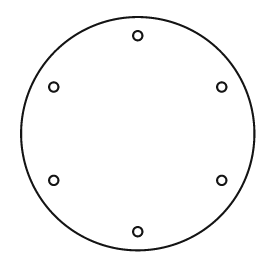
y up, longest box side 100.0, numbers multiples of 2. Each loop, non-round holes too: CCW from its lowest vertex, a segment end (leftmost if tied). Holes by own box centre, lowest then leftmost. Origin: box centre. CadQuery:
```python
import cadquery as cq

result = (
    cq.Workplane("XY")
    .moveTo(0.0, 0.0)
    .circle(50.0)
    .moveTo(0.0, -42.0)
    .circle(2.0)
    .moveTo(-36.0, -20.0)
    .circle(2.0)
    .moveTo(36.0, -20.0)
    .circle(2.0)
    .moveTo(-36.0, 20.0)
    .circle(2.0)
    .moveTo(36.0, 20.0)
    .circle(2.0)
    .moveTo(0.0, 42.0)
    .circle(2.0)
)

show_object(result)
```